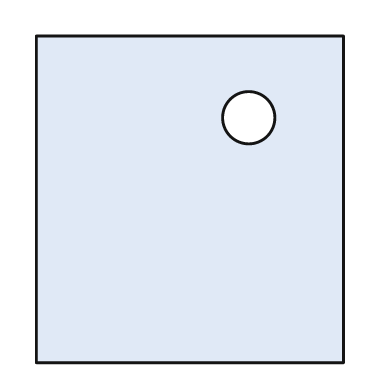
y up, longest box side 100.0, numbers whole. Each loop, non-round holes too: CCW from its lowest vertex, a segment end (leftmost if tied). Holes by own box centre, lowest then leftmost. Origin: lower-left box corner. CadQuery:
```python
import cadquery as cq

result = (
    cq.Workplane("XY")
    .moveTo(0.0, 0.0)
    .lineTo(94.0, 0.0)
    .lineTo(94.0, 100.0)
    .lineTo(0.0, 100.0)
    .close()
    .moveTo(65.0, 75.0)
    .circle(8.0)
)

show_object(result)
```